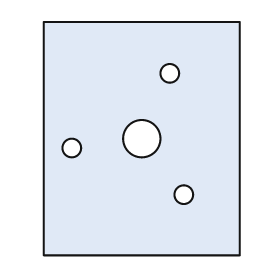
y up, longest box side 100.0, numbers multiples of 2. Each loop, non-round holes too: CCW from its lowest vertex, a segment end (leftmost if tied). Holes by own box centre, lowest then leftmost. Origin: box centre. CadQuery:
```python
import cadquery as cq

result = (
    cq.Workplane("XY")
    .moveTo(-42.0, -50.0)
    .lineTo(42.0, -50.0)
    .lineTo(42.0, 50.0)
    .lineTo(-42.0, 50.0)
    .close()
    .moveTo(18.0, -24.0)
    .circle(4.0)
    .moveTo(-30.0, -4.0)
    .circle(4.0)
    .moveTo(0.0, 0.0)
    .circle(8.0)
    .moveTo(12.0, 28.0)
    .circle(4.0)
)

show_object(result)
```